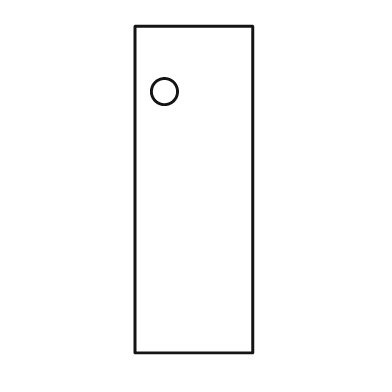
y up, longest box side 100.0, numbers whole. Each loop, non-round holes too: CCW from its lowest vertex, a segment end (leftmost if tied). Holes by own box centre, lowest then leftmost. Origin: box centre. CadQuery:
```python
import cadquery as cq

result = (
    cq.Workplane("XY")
    .moveTo(-18.0, -50.0)
    .lineTo(18.0, -50.0)
    .lineTo(18.0, 50.0)
    .lineTo(-18.0, 50.0)
    .close()
    .moveTo(-9.0, 30.0)
    .circle(4.0)
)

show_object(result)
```